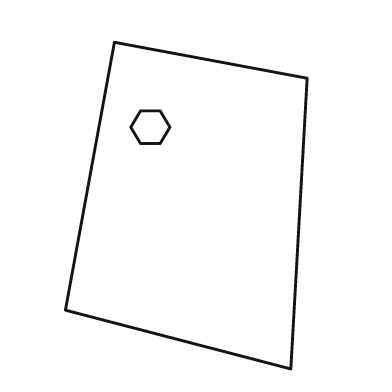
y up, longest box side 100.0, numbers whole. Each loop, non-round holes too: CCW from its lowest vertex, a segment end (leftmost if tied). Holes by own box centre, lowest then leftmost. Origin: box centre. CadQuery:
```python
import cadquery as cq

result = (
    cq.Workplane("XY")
    .moveTo(32.0, -50.0)
    .lineTo(37.0, 39.0)
    .lineTo(-22.0, 50.0)
    .lineTo(-37.0, -32.0)
    .close()
    .moveTo(-14.0, 19.0)
    .lineTo(-8.0, 19.0)
    .lineTo(-5.0, 24.0)
    .lineTo(-8.0, 29.0)
    .lineTo(-14.0, 29.0)
    .lineTo(-17.0, 24.0)
    .close()
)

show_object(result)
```